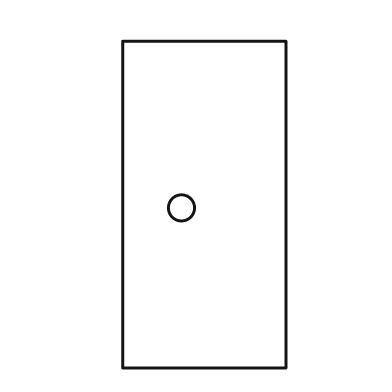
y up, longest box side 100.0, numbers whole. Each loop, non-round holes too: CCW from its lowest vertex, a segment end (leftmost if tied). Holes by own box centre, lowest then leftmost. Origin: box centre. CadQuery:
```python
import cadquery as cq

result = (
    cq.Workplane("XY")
    .moveTo(-25.0, -50.0)
    .lineTo(25.0, -50.0)
    .lineTo(25.0, 50.0)
    .lineTo(-25.0, 50.0)
    .close()
    .moveTo(-7.0, -1.0)
    .circle(4.0)
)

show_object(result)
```